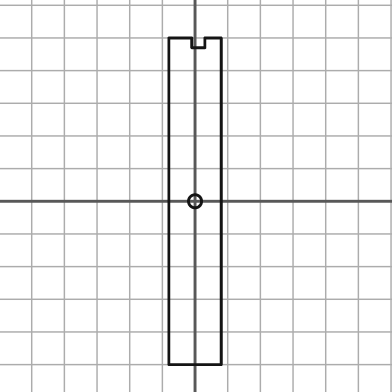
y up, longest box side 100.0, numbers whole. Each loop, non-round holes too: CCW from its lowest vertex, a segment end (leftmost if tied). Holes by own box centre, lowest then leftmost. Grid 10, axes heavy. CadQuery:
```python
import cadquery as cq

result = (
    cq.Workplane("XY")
    .moveTo(-8.0, -50.0)
    .lineTo(8.0, -50.0)
    .lineTo(8.0, 50.0)
    .lineTo(3.0, 50.0)
    .lineTo(3.0, 47.0)
    .lineTo(-1.0, 47.0)
    .lineTo(-1.0, 50.0)
    .lineTo(-8.0, 50.0)
    .close()
    .moveTo(0.0, 0.0)
    .circle(2.0)
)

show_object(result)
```